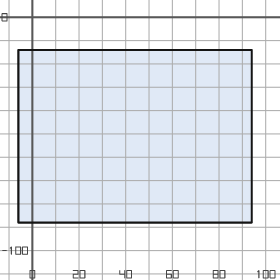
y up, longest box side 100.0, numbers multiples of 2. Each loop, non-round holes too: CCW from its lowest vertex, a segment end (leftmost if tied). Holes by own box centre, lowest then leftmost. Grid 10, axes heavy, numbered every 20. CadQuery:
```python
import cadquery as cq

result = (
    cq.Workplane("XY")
    .moveTo(-6.0, -88.0)
    .lineTo(94.0, -88.0)
    .lineTo(94.0, -14.0)
    .lineTo(-6.0, -14.0)
    .close()
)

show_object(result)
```